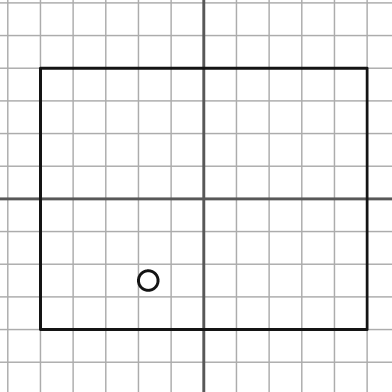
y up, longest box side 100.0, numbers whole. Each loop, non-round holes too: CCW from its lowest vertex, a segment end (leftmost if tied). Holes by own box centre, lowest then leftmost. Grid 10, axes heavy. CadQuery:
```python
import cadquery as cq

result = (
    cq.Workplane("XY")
    .moveTo(-50.0, -40.0)
    .lineTo(50.0, -40.0)
    .lineTo(50.0, 40.0)
    .lineTo(-50.0, 40.0)
    .close()
    .moveTo(-17.0, -25.0)
    .circle(3.0)
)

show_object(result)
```